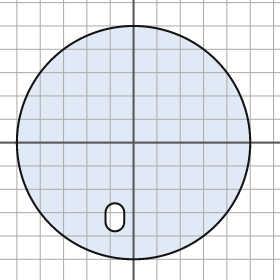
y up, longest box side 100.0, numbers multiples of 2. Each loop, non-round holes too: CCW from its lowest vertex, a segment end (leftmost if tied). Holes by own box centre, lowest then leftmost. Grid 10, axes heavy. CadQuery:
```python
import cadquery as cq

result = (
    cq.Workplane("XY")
    .moveTo(0.0, 0.0)
    .circle(50.0)
    .moveTo(-12.0, -34.0)
    .threePointArc((-8.0, -38.0), (-4.0, -34.0))
    .lineTo(-4.0, -30.0)
    .threePointArc((-8.0, -26.0), (-12.0, -30.0))
    .close()
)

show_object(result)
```